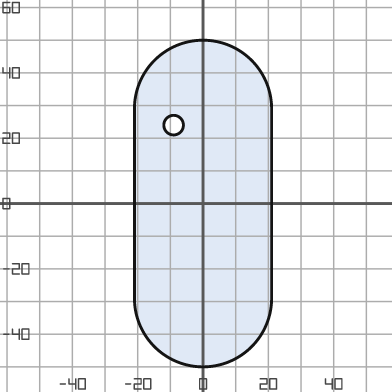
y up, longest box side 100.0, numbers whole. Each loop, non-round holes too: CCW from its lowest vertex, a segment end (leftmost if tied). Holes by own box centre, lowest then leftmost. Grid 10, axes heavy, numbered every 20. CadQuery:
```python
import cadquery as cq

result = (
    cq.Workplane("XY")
    .moveTo(-21.0, -29.0)
    .threePointArc((0.0, -50.0), (21.0, -29.0))
    .lineTo(21.0, 29.0)
    .threePointArc((0.0, 50.0), (-21.0, 29.0))
    .close()
    .moveTo(-9.0, 24.0)
    .circle(3.0)
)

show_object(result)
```